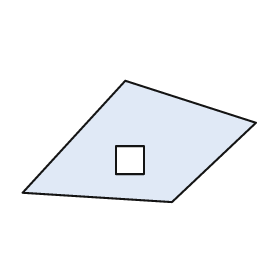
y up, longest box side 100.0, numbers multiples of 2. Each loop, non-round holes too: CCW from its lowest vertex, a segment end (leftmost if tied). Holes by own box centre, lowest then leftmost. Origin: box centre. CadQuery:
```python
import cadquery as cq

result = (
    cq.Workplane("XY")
    .moveTo(14.0, -26.0)
    .lineTo(50.0, 8.0)
    .lineTo(-6.0, 26.0)
    .lineTo(-50.0, -22.0)
    .close()
    .moveTo(-10.0, -14.0)
    .lineTo(2.0, -14.0)
    .lineTo(2.0, -2.0)
    .lineTo(-10.0, -2.0)
    .close()
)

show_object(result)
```